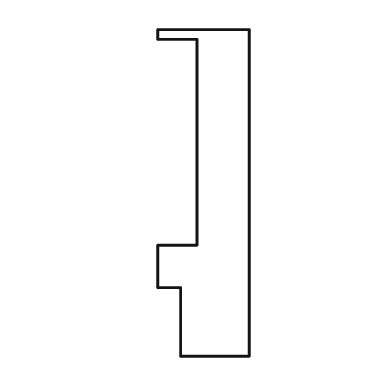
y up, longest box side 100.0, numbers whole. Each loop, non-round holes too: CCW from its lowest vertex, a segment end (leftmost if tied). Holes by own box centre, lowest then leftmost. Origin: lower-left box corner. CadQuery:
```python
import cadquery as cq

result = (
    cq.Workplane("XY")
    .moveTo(7.0, 0.0)
    .lineTo(28.0, 0.0)
    .lineTo(28.0, 100.0)
    .lineTo(0.0, 100.0)
    .lineTo(0.0, 97.0)
    .lineTo(12.0, 97.0)
    .lineTo(12.0, 34.0)
    .lineTo(0.0, 34.0)
    .lineTo(0.0, 21.0)
    .lineTo(7.0, 21.0)
    .close()
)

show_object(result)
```